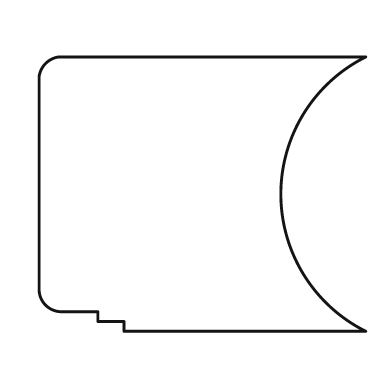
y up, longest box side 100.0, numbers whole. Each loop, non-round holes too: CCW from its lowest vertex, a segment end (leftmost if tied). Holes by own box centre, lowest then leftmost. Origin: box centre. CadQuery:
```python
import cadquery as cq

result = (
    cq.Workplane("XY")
    .moveTo(-24.0, -42.0)
    .lineTo(50.0, -42.0)
    .threePointArc((24.0, 0.0), (50.0, 42.0))
    .lineTo(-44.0, 42.0)
    .threePointArc((-48.0, 40.0), (-50.0, 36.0))
    .lineTo(-50.0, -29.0)
    .threePointArc((-48.0, -34.0), (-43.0, -36.0))
    .lineTo(-32.0, -36.0)
    .lineTo(-32.0, -39.0)
    .lineTo(-24.0, -39.0)
    .close()
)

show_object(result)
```